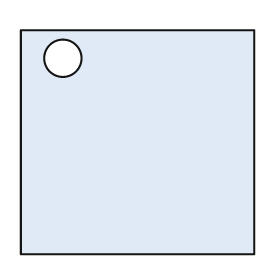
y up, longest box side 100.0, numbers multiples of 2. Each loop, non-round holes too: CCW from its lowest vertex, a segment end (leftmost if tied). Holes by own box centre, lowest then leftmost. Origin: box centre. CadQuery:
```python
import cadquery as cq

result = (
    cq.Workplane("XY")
    .moveTo(-50.0, -48.0)
    .lineTo(50.0, -48.0)
    .lineTo(50.0, 48.0)
    .lineTo(-50.0, 48.0)
    .close()
    .moveTo(-32.0, 36.0)
    .circle(8.0)
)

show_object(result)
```